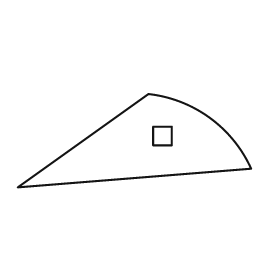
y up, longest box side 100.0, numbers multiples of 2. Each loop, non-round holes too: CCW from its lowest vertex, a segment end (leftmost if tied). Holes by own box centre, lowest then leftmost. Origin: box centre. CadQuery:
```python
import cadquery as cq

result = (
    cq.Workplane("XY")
    .moveTo(-50.0, -20.0)
    .lineTo(50.0, -12.0)
    .threePointArc((32.0, 10.0), (6.0, 20.0))
    .close()
    .moveTo(8.0, -2.0)
    .lineTo(16.0, -2.0)
    .lineTo(16.0, 6.0)
    .lineTo(8.0, 6.0)
    .close()
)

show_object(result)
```